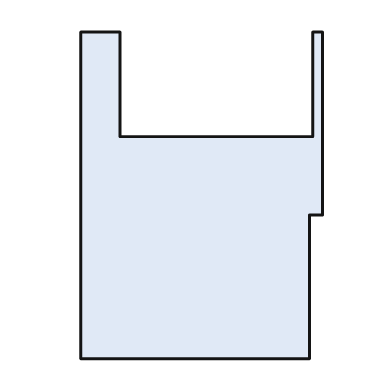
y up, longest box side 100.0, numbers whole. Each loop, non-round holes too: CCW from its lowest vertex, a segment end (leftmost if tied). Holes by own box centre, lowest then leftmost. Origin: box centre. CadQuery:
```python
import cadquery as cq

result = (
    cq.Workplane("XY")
    .moveTo(-37.0, -50.0)
    .lineTo(33.0, -50.0)
    .lineTo(33.0, -6.0)
    .lineTo(37.0, -6.0)
    .lineTo(37.0, 50.0)
    .lineTo(34.0, 50.0)
    .lineTo(34.0, 18.0)
    .lineTo(-25.0, 18.0)
    .lineTo(-25.0, 50.0)
    .lineTo(-37.0, 50.0)
    .close()
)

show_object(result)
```